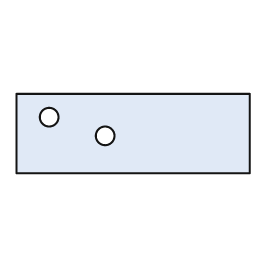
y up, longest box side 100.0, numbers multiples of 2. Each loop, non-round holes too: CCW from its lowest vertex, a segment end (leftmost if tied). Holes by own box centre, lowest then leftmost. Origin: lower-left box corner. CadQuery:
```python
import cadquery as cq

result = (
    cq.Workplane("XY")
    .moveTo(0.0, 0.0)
    .lineTo(100.0, 0.0)
    .lineTo(100.0, 34.0)
    .lineTo(0.0, 34.0)
    .close()
    .moveTo(38.0, 16.0)
    .circle(4.0)
    .moveTo(14.0, 24.0)
    .circle(4.0)
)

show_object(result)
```